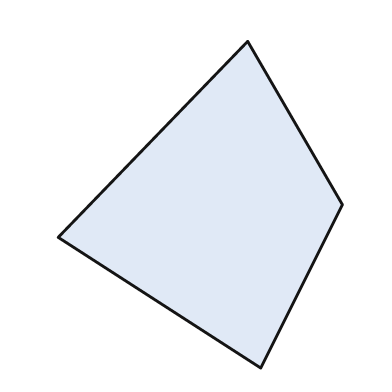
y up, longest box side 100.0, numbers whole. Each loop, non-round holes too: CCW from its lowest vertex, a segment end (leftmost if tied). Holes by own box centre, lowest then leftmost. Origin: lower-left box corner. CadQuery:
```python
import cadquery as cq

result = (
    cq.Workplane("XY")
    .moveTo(62.0, 0.0)
    .lineTo(87.0, 50.0)
    .lineTo(58.0, 100.0)
    .lineTo(0.0, 40.0)
    .close()
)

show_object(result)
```